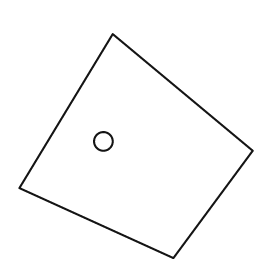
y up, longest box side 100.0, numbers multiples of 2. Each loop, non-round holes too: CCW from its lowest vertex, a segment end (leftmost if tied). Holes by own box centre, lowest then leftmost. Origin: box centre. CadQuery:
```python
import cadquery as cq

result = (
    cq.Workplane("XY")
    .moveTo(16.0, -48.0)
    .lineTo(50.0, -2.0)
    .lineTo(-10.0, 48.0)
    .lineTo(-50.0, -18.0)
    .close()
    .moveTo(-14.0, 2.0)
    .circle(4.0)
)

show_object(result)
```